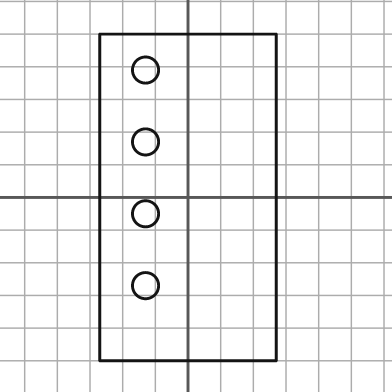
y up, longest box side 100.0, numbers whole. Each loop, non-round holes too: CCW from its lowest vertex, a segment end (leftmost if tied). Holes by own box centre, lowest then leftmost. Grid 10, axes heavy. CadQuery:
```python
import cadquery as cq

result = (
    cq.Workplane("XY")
    .moveTo(-27.0, -50.0)
    .lineTo(27.0, -50.0)
    .lineTo(27.0, 50.0)
    .lineTo(-27.0, 50.0)
    .close()
    .moveTo(-13.0, -27.0)
    .circle(4.0)
    .moveTo(-13.0, -5.0)
    .circle(4.0)
    .moveTo(-13.0, 17.0)
    .circle(4.0)
    .moveTo(-13.0, 39.0)
    .circle(4.0)
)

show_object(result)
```